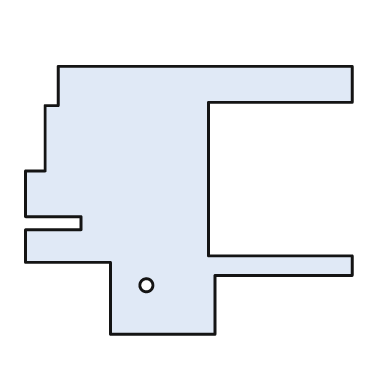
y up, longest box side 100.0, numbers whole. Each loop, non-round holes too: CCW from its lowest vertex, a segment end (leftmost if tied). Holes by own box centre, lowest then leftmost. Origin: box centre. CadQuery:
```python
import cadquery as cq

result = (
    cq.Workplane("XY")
    .moveTo(-24.0, -41.0)
    .lineTo(8.0, -41.0)
    .lineTo(8.0, -23.0)
    .lineTo(50.0, -23.0)
    .lineTo(50.0, -17.0)
    .lineTo(6.0, -17.0)
    .lineTo(6.0, 30.0)
    .lineTo(50.0, 30.0)
    .lineTo(50.0, 41.0)
    .lineTo(-40.0, 41.0)
    .lineTo(-40.0, 29.0)
    .lineTo(-44.0, 29.0)
    .lineTo(-44.0, 9.0)
    .lineTo(-50.0, 9.0)
    .lineTo(-50.0, -5.0)
    .lineTo(-33.0, -5.0)
    .lineTo(-33.0, -9.0)
    .lineTo(-50.0, -9.0)
    .lineTo(-50.0, -19.0)
    .lineTo(-24.0, -19.0)
    .close()
    .moveTo(-13.0, -26.0)
    .circle(2.0)
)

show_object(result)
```